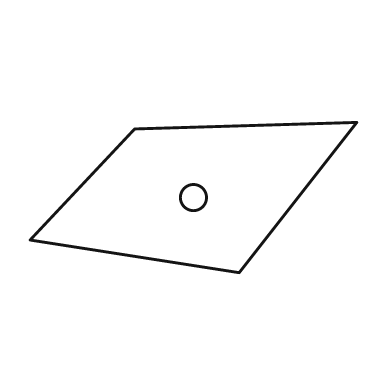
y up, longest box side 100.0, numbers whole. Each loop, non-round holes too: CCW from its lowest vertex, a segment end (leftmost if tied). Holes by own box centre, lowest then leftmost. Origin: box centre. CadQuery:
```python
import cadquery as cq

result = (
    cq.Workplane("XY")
    .moveTo(14.0, -23.0)
    .lineTo(50.0, 23.0)
    .lineTo(-18.0, 21.0)
    .lineTo(-50.0, -13.0)
    .close()
    .moveTo(0.0, 0.0)
    .circle(4.0)
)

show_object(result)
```